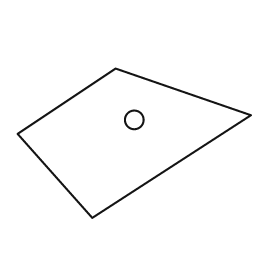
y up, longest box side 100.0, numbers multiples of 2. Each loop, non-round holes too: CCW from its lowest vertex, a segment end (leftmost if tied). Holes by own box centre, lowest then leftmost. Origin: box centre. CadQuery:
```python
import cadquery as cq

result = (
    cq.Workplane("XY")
    .moveTo(-18.0, -32.0)
    .lineTo(50.0, 12.0)
    .lineTo(-8.0, 32.0)
    .lineTo(-50.0, 4.0)
    .close()
    .moveTo(0.0, 10.0)
    .circle(4.0)
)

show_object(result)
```